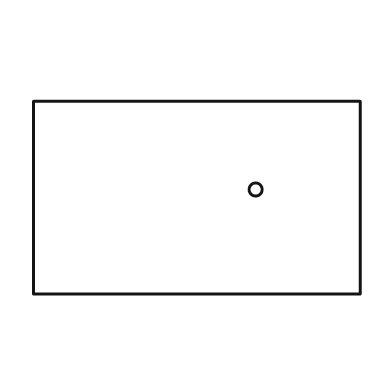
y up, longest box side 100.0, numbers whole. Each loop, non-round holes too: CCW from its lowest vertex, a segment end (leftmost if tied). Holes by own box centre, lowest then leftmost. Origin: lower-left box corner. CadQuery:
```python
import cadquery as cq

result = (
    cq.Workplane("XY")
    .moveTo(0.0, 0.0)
    .lineTo(100.0, 0.0)
    .lineTo(100.0, 59.0)
    .lineTo(0.0, 59.0)
    .close()
    .moveTo(68.0, 32.0)
    .circle(2.0)
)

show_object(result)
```